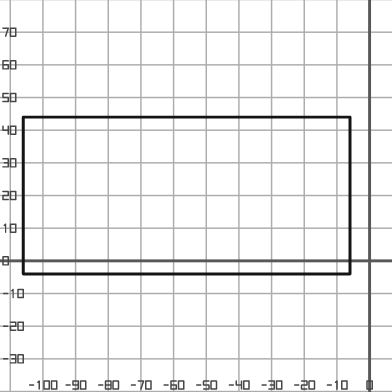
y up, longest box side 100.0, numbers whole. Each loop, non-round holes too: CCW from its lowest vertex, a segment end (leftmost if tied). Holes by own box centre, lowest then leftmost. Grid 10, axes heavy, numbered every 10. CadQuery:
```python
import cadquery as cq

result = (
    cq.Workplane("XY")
    .moveTo(-106.0, -4.0)
    .lineTo(-6.0, -4.0)
    .lineTo(-6.0, 44.0)
    .lineTo(-106.0, 44.0)
    .close()
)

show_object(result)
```